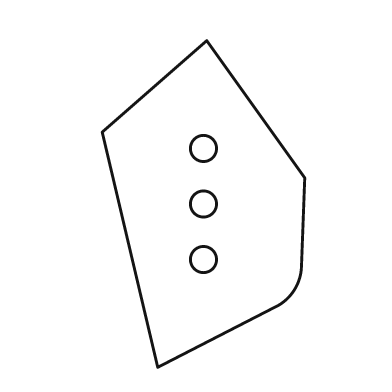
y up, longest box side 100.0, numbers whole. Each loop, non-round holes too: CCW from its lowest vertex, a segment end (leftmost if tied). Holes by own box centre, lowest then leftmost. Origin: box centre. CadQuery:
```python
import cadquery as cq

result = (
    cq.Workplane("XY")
    .moveTo(-14.0, -50.0)
    .lineTo(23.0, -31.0)
    .threePointArc((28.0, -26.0), (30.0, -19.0))
    .lineTo(31.0, 8.0)
    .lineTo(1.0, 50.0)
    .lineTo(-31.0, 22.0)
    .close()
    .moveTo(0.0, -17.0)
    .circle(4.0)
    .moveTo(0.0, 0.0)
    .circle(4.0)
    .moveTo(0.0, 17.0)
    .circle(4.0)
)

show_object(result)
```